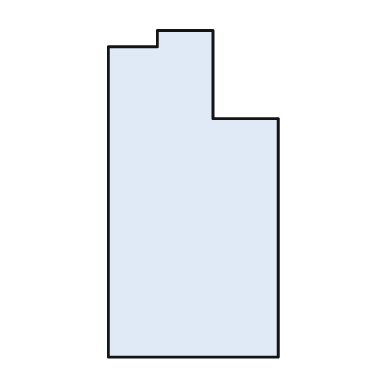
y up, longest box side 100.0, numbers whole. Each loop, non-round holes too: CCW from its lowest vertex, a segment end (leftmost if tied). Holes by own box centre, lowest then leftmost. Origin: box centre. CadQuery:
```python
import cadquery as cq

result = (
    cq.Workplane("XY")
    .moveTo(-26.0, -50.0)
    .lineTo(26.0, -50.0)
    .lineTo(26.0, 23.0)
    .lineTo(6.0, 23.0)
    .lineTo(6.0, 50.0)
    .lineTo(-11.0, 50.0)
    .lineTo(-11.0, 45.0)
    .lineTo(-26.0, 45.0)
    .close()
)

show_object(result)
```